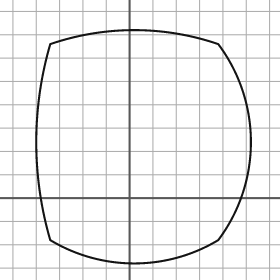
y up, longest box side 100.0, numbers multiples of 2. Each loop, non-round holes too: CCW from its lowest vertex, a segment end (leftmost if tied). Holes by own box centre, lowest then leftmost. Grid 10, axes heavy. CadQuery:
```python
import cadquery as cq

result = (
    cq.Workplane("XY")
    .moveTo(-34.0, -18.0)
    .threePointArc((2.0, -28.0), (38.0, -18.0))
    .threePointArc((52.0, 24.0), (38.0, 66.0))
    .threePointArc((2.0, 72.0), (-34.0, 66.0))
    .threePointArc((-40.0, 24.0), (-34.0, -18.0))
    .close()
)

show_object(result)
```